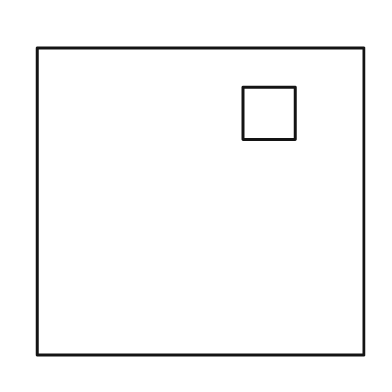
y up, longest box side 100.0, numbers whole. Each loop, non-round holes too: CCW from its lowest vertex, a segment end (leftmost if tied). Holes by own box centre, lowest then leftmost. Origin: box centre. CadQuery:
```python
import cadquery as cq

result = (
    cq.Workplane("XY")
    .moveTo(-50.0, -47.0)
    .lineTo(50.0, -47.0)
    .lineTo(50.0, 47.0)
    .lineTo(-50.0, 47.0)
    .close()
    .moveTo(13.0, 19.0)
    .lineTo(29.0, 19.0)
    .lineTo(29.0, 35.0)
    .lineTo(13.0, 35.0)
    .close()
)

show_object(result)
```